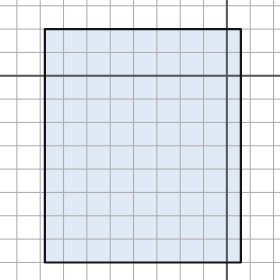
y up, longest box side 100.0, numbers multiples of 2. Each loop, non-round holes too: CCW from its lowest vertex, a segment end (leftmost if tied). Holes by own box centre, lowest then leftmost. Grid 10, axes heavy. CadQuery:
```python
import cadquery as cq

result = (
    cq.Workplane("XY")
    .moveTo(-78.0, -80.0)
    .lineTo(6.0, -80.0)
    .lineTo(6.0, 20.0)
    .lineTo(-78.0, 20.0)
    .close()
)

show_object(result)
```